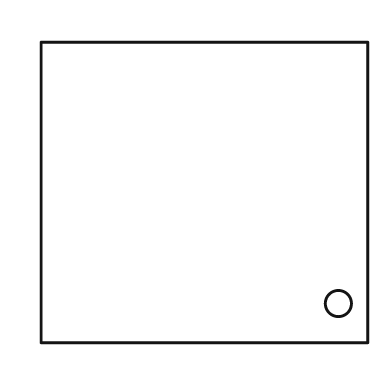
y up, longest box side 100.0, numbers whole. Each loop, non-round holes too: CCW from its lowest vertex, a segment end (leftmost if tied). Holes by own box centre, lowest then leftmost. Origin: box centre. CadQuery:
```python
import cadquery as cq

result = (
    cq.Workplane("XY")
    .moveTo(-50.0, -46.0)
    .lineTo(50.0, -46.0)
    .lineTo(50.0, 46.0)
    .lineTo(-50.0, 46.0)
    .close()
    .moveTo(41.0, -34.0)
    .circle(4.0)
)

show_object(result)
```